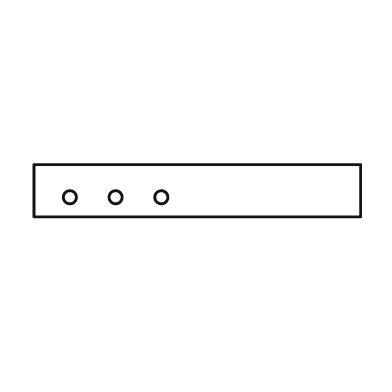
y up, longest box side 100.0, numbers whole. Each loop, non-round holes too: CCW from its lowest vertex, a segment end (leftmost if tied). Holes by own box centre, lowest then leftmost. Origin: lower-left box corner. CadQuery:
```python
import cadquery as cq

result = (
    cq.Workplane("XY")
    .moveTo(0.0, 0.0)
    .lineTo(100.0, 0.0)
    .lineTo(100.0, 16.0)
    .lineTo(0.0, 16.0)
    .close()
    .moveTo(11.0, 6.0)
    .circle(2.0)
    .moveTo(25.0, 6.0)
    .circle(2.0)
    .moveTo(39.0, 6.0)
    .circle(2.0)
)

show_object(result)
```